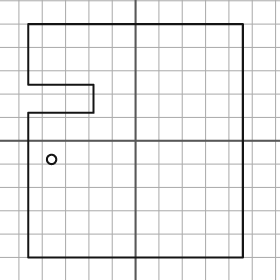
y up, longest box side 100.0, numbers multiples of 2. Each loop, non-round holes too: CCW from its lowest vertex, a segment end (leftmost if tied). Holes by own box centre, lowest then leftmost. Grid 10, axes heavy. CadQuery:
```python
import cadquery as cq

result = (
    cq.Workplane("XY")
    .moveTo(-46.0, -50.0)
    .lineTo(46.0, -50.0)
    .lineTo(46.0, 50.0)
    .lineTo(-46.0, 50.0)
    .lineTo(-46.0, 24.0)
    .lineTo(-18.0, 24.0)
    .lineTo(-18.0, 12.0)
    .lineTo(-46.0, 12.0)
    .close()
    .moveTo(-36.0, -8.0)
    .circle(2.0)
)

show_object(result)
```